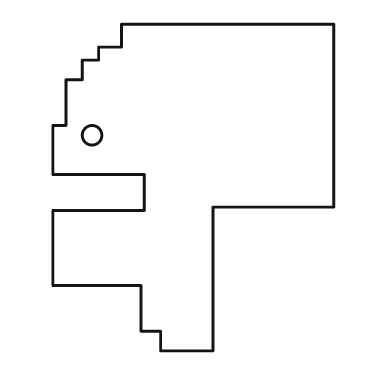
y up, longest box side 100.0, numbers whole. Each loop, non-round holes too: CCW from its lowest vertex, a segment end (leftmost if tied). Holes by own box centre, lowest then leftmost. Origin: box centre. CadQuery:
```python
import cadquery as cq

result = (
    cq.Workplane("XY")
    .moveTo(-10.0, -50.0)
    .lineTo(6.0, -50.0)
    .lineTo(6.0, -6.0)
    .lineTo(43.0, -6.0)
    .lineTo(43.0, 50.0)
    .lineTo(-22.0, 50.0)
    .lineTo(-22.0, 43.0)
    .lineTo(-29.0, 43.0)
    .lineTo(-29.0, 39.0)
    .lineTo(-34.0, 39.0)
    .lineTo(-34.0, 33.0)
    .lineTo(-39.0, 33.0)
    .lineTo(-39.0, 19.0)
    .lineTo(-43.0, 19.0)
    .lineTo(-43.0, 4.0)
    .lineTo(-15.0, 4.0)
    .lineTo(-15.0, -7.0)
    .lineTo(-43.0, -7.0)
    .lineTo(-43.0, -30.0)
    .lineTo(-16.0, -30.0)
    .lineTo(-16.0, -44.0)
    .lineTo(-10.0, -44.0)
    .close()
    .moveTo(-31.0, 16.0)
    .circle(3.0)
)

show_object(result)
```